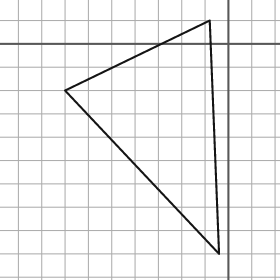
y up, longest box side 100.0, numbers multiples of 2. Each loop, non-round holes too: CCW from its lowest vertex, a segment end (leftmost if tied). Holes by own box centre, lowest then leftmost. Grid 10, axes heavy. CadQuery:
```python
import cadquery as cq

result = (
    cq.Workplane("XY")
    .moveTo(-4.0, -90.0)
    .lineTo(-8.0, 10.0)
    .lineTo(-70.0, -20.0)
    .close()
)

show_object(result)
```